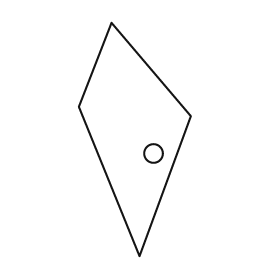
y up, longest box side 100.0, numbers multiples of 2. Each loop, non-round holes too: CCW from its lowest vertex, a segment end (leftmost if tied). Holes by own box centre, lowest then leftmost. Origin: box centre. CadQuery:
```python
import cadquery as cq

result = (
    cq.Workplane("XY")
    .moveTo(2.0, -50.0)
    .lineTo(24.0, 10.0)
    .lineTo(-10.0, 50.0)
    .lineTo(-24.0, 14.0)
    .close()
    .moveTo(8.0, -6.0)
    .circle(4.0)
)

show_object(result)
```